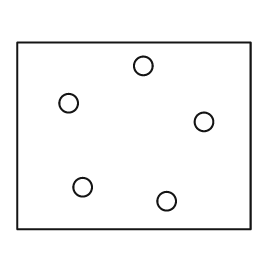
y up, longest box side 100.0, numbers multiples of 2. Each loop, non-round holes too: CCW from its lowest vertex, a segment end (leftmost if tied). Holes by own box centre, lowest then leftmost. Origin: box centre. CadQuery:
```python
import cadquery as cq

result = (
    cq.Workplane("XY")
    .moveTo(-50.0, -40.0)
    .lineTo(50.0, -40.0)
    .lineTo(50.0, 40.0)
    .lineTo(-50.0, 40.0)
    .close()
    .moveTo(14.0, -28.0)
    .circle(4.0)
    .moveTo(-22.0, -22.0)
    .circle(4.0)
    .moveTo(30.0, 6.0)
    .circle(4.0)
    .moveTo(-28.0, 14.0)
    .circle(4.0)
    .moveTo(4.0, 30.0)
    .circle(4.0)
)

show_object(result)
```